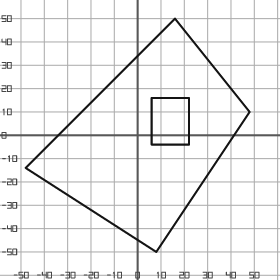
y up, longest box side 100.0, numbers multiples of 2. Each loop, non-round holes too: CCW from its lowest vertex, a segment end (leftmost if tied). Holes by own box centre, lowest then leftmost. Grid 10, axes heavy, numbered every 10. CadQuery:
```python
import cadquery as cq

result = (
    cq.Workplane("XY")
    .moveTo(8.0, -50.0)
    .lineTo(48.0, 10.0)
    .lineTo(16.0, 50.0)
    .lineTo(-48.0, -14.0)
    .close()
    .moveTo(6.0, -4.0)
    .lineTo(22.0, -4.0)
    .lineTo(22.0, 16.0)
    .lineTo(6.0, 16.0)
    .close()
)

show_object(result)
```